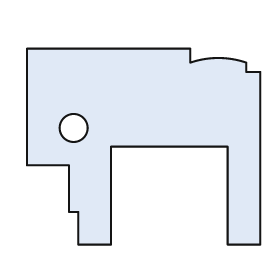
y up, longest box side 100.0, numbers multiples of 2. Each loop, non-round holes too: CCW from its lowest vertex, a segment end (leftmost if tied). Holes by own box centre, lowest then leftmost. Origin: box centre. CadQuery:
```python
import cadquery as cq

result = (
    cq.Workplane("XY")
    .moveTo(-28.0, -42.0)
    .lineTo(-14.0, -42.0)
    .lineTo(-14.0, 0.0)
    .lineTo(36.0, 0.0)
    .lineTo(36.0, -42.0)
    .lineTo(50.0, -42.0)
    .lineTo(50.0, 32.0)
    .lineTo(44.0, 32.0)
    .lineTo(44.0, 36.0)
    .threePointArc((32.0, 38.0), (20.0, 36.0))
    .lineTo(20.0, 42.0)
    .lineTo(-50.0, 42.0)
    .lineTo(-50.0, -8.0)
    .lineTo(-32.0, -8.0)
    .lineTo(-32.0, -28.0)
    .lineTo(-28.0, -28.0)
    .close()
    .moveTo(-30.0, 8.0)
    .circle(6.0)
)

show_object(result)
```